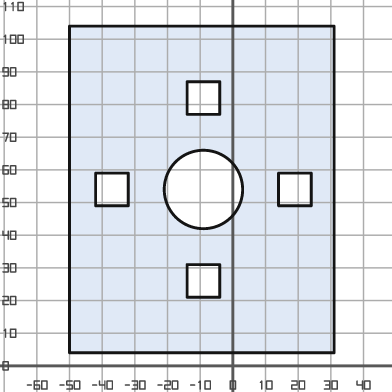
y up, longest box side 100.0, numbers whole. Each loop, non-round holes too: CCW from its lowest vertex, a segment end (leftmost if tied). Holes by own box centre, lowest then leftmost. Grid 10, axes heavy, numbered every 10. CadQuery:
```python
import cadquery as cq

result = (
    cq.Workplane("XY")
    .moveTo(-50.0, 4.0)
    .lineTo(31.0, 4.0)
    .lineTo(31.0, 104.0)
    .lineTo(-50.0, 104.0)
    .close()
    .moveTo(-14.0, 21.0)
    .lineTo(-4.0, 21.0)
    .lineTo(-4.0, 31.0)
    .lineTo(-14.0, 31.0)
    .close()
    .moveTo(-42.0, 49.0)
    .lineTo(-32.0, 49.0)
    .lineTo(-32.0, 59.0)
    .lineTo(-42.0, 59.0)
    .close()
    .moveTo(-9.0, 54.0)
    .circle(12.0)
    .moveTo(14.0, 49.0)
    .lineTo(24.0, 49.0)
    .lineTo(24.0, 59.0)
    .lineTo(14.0, 59.0)
    .close()
    .moveTo(-14.0, 77.0)
    .lineTo(-4.0, 77.0)
    .lineTo(-4.0, 87.0)
    .lineTo(-14.0, 87.0)
    .close()
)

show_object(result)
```